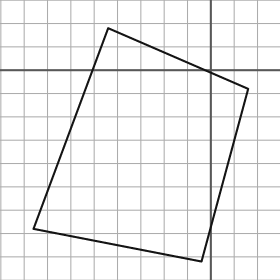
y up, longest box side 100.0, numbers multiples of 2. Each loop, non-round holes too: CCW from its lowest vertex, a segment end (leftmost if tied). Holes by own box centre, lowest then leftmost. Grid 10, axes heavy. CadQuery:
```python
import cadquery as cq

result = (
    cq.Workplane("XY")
    .moveTo(-4.0, -82.0)
    .lineTo(16.0, -8.0)
    .lineTo(-44.0, 18.0)
    .lineTo(-76.0, -68.0)
    .close()
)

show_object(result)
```